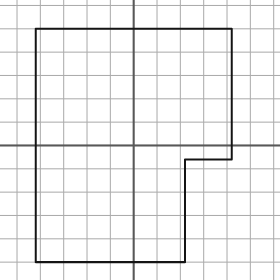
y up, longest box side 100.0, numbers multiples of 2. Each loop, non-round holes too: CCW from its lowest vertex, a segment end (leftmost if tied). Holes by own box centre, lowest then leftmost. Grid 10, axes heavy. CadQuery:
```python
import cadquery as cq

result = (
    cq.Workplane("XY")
    .moveTo(-42.0, -50.0)
    .lineTo(22.0, -50.0)
    .lineTo(22.0, -6.0)
    .lineTo(42.0, -6.0)
    .lineTo(42.0, 50.0)
    .lineTo(-42.0, 50.0)
    .close()
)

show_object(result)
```